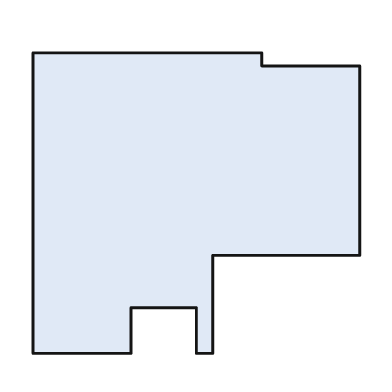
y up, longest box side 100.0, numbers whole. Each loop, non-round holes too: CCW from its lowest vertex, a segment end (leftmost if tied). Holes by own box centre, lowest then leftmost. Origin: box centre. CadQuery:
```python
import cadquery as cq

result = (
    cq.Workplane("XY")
    .moveTo(-50.0, -46.0)
    .lineTo(-20.0, -46.0)
    .lineTo(-20.0, -32.0)
    .lineTo(0.0, -32.0)
    .lineTo(0.0, -46.0)
    .lineTo(5.0, -46.0)
    .lineTo(5.0, -16.0)
    .lineTo(50.0, -16.0)
    .lineTo(50.0, 42.0)
    .lineTo(20.0, 42.0)
    .lineTo(20.0, 46.0)
    .lineTo(-50.0, 46.0)
    .close()
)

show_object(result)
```